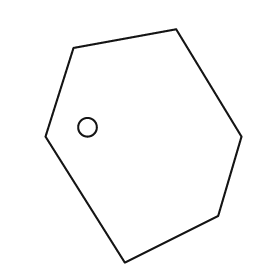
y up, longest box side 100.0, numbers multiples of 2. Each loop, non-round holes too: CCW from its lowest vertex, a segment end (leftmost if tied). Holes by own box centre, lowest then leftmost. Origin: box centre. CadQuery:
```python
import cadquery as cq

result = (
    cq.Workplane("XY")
    .moveTo(-8.0, -50.0)
    .lineTo(32.0, -30.0)
    .lineTo(42.0, 4.0)
    .lineTo(14.0, 50.0)
    .lineTo(-30.0, 42.0)
    .lineTo(-42.0, 4.0)
    .close()
    .moveTo(-24.0, 8.0)
    .circle(4.0)
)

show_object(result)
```